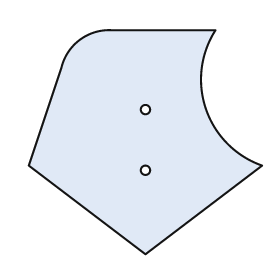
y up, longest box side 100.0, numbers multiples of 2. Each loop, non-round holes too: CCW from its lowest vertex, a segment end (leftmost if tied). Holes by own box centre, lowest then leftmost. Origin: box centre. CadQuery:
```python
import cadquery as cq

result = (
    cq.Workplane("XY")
    .moveTo(0.0, -48.0)
    .lineTo(50.0, -10.0)
    .threePointArc((26.0, 14.0), (30.0, 48.0))
    .lineTo(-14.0, 48.0)
    .threePointArc((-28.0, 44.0), (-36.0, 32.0))
    .lineTo(-50.0, -10.0)
    .close()
    .moveTo(0.0, -12.0)
    .circle(2.0)
    .moveTo(0.0, 14.0)
    .circle(2.0)
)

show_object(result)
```